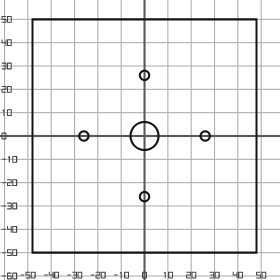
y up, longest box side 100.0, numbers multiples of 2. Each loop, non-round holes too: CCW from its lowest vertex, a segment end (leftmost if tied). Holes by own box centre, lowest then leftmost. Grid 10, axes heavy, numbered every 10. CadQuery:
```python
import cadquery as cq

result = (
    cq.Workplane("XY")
    .moveTo(-48.0, -50.0)
    .lineTo(48.0, -50.0)
    .lineTo(48.0, 50.0)
    .lineTo(-48.0, 50.0)
    .close()
    .moveTo(0.0, -26.0)
    .circle(2.0)
    .moveTo(-26.0, 0.0)
    .circle(2.0)
    .moveTo(0.0, 0.0)
    .circle(6.0)
    .moveTo(26.0, 0.0)
    .circle(2.0)
    .moveTo(0.0, 26.0)
    .circle(2.0)
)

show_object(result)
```